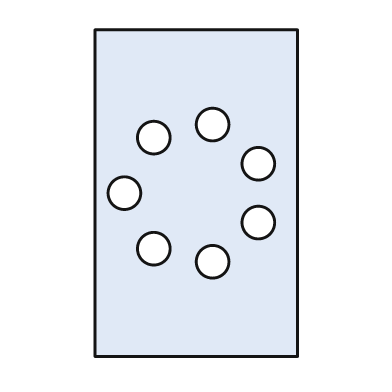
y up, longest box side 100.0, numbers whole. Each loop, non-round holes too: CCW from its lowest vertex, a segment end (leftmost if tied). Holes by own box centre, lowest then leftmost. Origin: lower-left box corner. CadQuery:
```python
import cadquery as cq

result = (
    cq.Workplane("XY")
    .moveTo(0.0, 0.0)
    .lineTo(62.0, 0.0)
    .lineTo(62.0, 100.0)
    .lineTo(0.0, 100.0)
    .close()
    .moveTo(36.0, 29.0)
    .circle(5.0)
    .moveTo(18.0, 33.0)
    .circle(5.0)
    .moveTo(50.0, 41.0)
    .circle(5.0)
    .moveTo(9.0, 50.0)
    .circle(5.0)
    .moveTo(50.0, 59.0)
    .circle(5.0)
    .moveTo(18.0, 67.0)
    .circle(5.0)
    .moveTo(36.0, 71.0)
    .circle(5.0)
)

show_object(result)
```